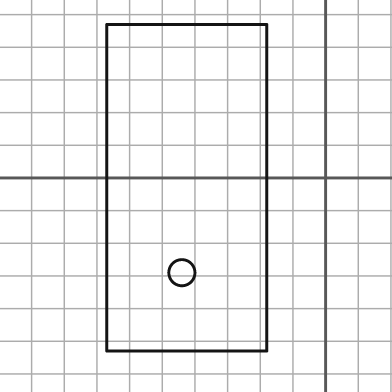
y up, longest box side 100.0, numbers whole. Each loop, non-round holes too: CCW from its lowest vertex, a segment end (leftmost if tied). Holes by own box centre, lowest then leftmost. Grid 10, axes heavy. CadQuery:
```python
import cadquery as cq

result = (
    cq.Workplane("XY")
    .moveTo(-67.0, -53.0)
    .lineTo(-18.0, -53.0)
    .lineTo(-18.0, 47.0)
    .lineTo(-67.0, 47.0)
    .close()
    .moveTo(-44.0, -29.0)
    .circle(4.0)
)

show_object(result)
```